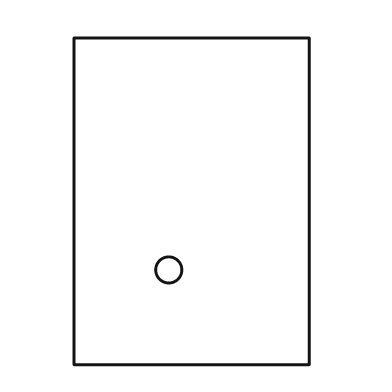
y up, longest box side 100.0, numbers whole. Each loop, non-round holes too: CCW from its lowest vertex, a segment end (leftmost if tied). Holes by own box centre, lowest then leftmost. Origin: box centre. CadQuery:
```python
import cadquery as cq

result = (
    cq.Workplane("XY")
    .moveTo(-36.0, -50.0)
    .lineTo(36.0, -50.0)
    .lineTo(36.0, 50.0)
    .lineTo(-36.0, 50.0)
    .close()
    .moveTo(-7.0, -21.0)
    .circle(4.0)
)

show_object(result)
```